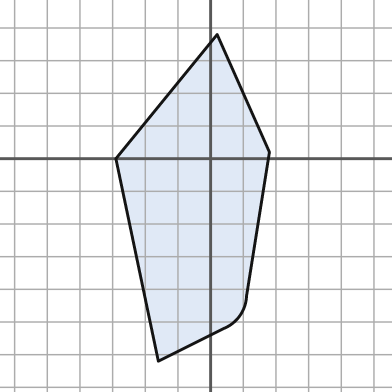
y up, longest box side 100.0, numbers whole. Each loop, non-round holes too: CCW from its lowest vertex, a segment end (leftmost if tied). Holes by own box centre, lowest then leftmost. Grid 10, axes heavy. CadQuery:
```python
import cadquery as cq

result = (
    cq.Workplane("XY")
    .moveTo(-16.0, -62.0)
    .lineTo(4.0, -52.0)
    .threePointArc((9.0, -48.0), (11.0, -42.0))
    .lineTo(18.0, 2.0)
    .lineTo(2.0, 38.0)
    .lineTo(-29.0, 0.0)
    .close()
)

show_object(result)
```